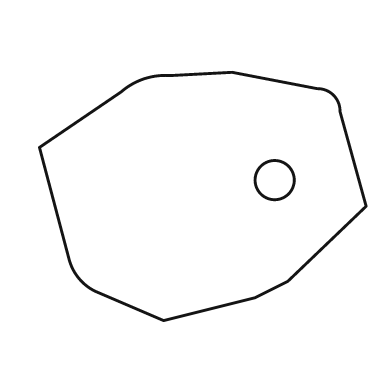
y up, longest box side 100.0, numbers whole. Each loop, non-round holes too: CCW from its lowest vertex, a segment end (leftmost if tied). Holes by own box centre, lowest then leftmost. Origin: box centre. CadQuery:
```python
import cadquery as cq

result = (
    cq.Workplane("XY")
    .moveTo(-12.0, -38.0)
    .lineTo(16.0, -31.0)
    .lineTo(26.0, -26.0)
    .lineTo(50.0, -3.0)
    .lineTo(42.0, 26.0)
    .threePointArc((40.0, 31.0), (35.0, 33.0))
    .lineTo(9.0, 38.0)
    .lineTo(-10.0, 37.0)
    .threePointArc((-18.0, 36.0), (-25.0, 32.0))
    .lineTo(-50.0, 15.0)
    .lineTo(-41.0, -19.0)
    .threePointArc((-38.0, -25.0), (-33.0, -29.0))
    .close()
    .moveTo(22.0, 5.0)
    .circle(6.0)
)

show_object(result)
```